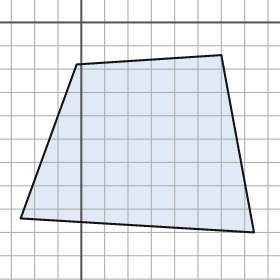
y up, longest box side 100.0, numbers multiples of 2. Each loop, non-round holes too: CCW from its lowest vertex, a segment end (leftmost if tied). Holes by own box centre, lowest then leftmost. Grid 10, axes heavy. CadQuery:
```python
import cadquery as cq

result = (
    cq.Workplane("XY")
    .moveTo(74.0, -90.0)
    .lineTo(60.0, -14.0)
    .lineTo(-2.0, -18.0)
    .lineTo(-26.0, -84.0)
    .close()
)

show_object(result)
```